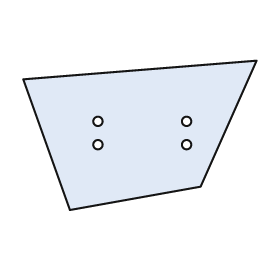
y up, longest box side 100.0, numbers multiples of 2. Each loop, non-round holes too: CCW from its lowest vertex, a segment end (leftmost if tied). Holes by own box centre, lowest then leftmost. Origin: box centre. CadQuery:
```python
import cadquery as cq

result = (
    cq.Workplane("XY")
    .moveTo(-30.0, -32.0)
    .lineTo(26.0, -22.0)
    .lineTo(50.0, 32.0)
    .lineTo(-50.0, 24.0)
    .close()
    .moveTo(-18.0, -4.0)
    .circle(2.0)
    .moveTo(20.0, -4.0)
    .circle(2.0)
    .moveTo(-18.0, 6.0)
    .circle(2.0)
    .moveTo(20.0, 6.0)
    .circle(2.0)
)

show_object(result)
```